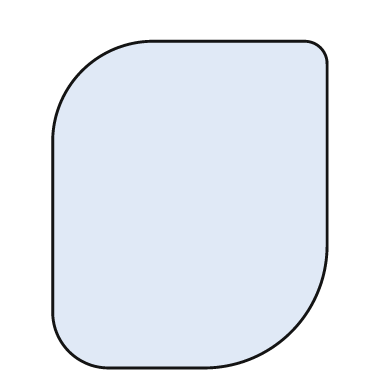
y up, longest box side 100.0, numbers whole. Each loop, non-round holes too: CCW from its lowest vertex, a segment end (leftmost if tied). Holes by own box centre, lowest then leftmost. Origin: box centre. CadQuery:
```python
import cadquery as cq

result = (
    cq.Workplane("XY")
    .moveTo(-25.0, -50.0)
    .lineTo(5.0, -50.0)
    .threePointArc((31.0, -39.0), (42.0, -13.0))
    .lineTo(42.0, 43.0)
    .threePointArc((40.0, 48.0), (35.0, 50.0))
    .lineTo(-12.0, 50.0)
    .threePointArc((-33.0, 41.0), (-42.0, 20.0))
    .lineTo(-42.0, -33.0)
    .threePointArc((-37.0, -45.0), (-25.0, -50.0))
    .close()
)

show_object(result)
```